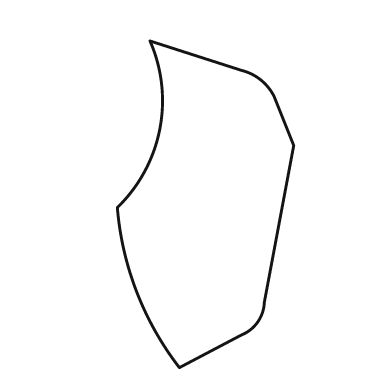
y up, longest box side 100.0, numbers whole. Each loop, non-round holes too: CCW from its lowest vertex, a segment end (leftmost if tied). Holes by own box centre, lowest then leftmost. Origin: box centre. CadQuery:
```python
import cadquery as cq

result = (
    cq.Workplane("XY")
    .moveTo(-8.0, -50.0)
    .lineTo(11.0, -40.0)
    .threePointArc((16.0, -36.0), (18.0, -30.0))
    .lineTo(27.0, 18.0)
    .lineTo(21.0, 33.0)
    .threePointArc((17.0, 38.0), (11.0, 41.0))
    .lineTo(-17.0, 50.0)
    .threePointArc((-14.0, 23.0), (-27.0, -1.0))
    .threePointArc((-21.0, -27.0), (-8.0, -50.0))
    .close()
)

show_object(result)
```